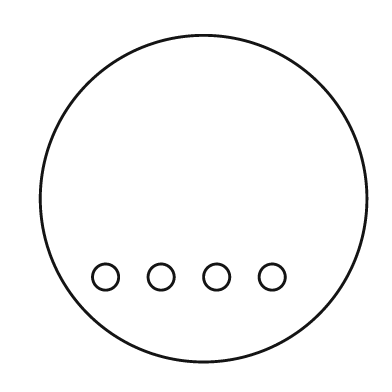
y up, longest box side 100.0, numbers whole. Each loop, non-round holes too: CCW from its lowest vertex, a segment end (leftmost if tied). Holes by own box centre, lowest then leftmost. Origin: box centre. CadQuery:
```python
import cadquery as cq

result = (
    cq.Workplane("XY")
    .moveTo(0.0, 0.0)
    .circle(50.0)
    .moveTo(-30.0, -24.0)
    .circle(4.0)
    .moveTo(-13.0, -24.0)
    .circle(4.0)
    .moveTo(4.0, -24.0)
    .circle(4.0)
    .moveTo(21.0, -24.0)
    .circle(4.0)
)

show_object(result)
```